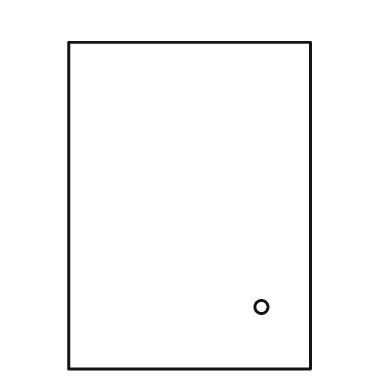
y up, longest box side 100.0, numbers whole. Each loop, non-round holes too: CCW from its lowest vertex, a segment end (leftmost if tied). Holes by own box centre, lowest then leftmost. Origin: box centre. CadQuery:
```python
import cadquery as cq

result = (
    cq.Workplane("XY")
    .moveTo(-37.0, -50.0)
    .lineTo(37.0, -50.0)
    .lineTo(37.0, 50.0)
    .lineTo(-37.0, 50.0)
    .close()
    .moveTo(22.0, -31.0)
    .circle(2.0)
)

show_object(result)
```